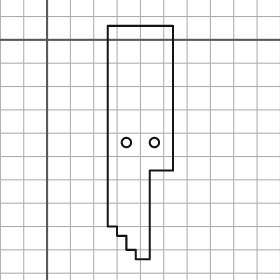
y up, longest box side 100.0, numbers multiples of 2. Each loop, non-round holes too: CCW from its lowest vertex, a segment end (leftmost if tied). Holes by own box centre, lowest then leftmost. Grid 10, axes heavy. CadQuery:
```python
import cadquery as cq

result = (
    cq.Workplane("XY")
    .moveTo(38.0, -94.0)
    .lineTo(44.0, -94.0)
    .lineTo(44.0, -56.0)
    .lineTo(54.0, -56.0)
    .lineTo(54.0, 6.0)
    .lineTo(26.0, 6.0)
    .lineTo(26.0, -80.0)
    .lineTo(30.0, -80.0)
    .lineTo(30.0, -84.0)
    .lineTo(34.0, -84.0)
    .lineTo(34.0, -90.0)
    .lineTo(38.0, -90.0)
    .close()
    .moveTo(34.0, -44.0)
    .circle(2.0)
    .moveTo(46.0, -44.0)
    .circle(2.0)
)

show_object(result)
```